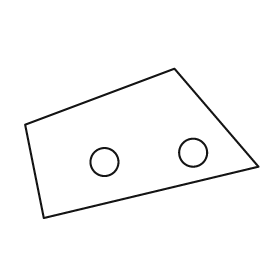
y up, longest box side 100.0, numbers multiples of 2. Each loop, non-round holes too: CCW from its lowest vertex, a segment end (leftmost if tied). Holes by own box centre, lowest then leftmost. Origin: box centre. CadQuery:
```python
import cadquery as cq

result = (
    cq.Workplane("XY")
    .moveTo(-42.0, -32.0)
    .lineTo(50.0, -10.0)
    .lineTo(14.0, 32.0)
    .lineTo(-50.0, 8.0)
    .close()
    .moveTo(-16.0, -8.0)
    .circle(6.0)
    .moveTo(22.0, -4.0)
    .circle(6.0)
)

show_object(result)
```